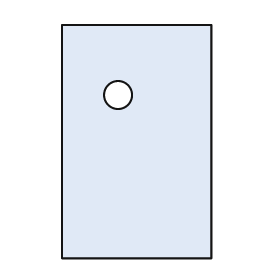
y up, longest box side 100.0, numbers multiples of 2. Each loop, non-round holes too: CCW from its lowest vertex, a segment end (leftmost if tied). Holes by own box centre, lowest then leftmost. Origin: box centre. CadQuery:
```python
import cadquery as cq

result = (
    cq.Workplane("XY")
    .moveTo(-32.0, -50.0)
    .lineTo(32.0, -50.0)
    .lineTo(32.0, 50.0)
    .lineTo(-32.0, 50.0)
    .close()
    .moveTo(-8.0, 20.0)
    .circle(6.0)
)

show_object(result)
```